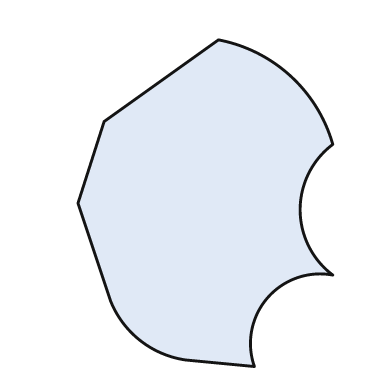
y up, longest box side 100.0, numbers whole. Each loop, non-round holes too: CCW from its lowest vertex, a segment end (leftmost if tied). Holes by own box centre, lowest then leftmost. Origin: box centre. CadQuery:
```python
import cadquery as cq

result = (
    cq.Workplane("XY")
    .moveTo(15.0, -50.0)
    .threePointArc((19.0, -29.0), (39.0, -22.0))
    .threePointArc((29.0, -2.0), (39.0, 18.0))
    .threePointArc((26.0, 39.0), (4.0, 50.0))
    .lineTo(-31.0, 25.0)
    .lineTo(-39.0, 0.0)
    .lineTo(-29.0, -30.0)
    .threePointArc((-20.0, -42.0), (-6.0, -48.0))
    .close()
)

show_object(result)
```